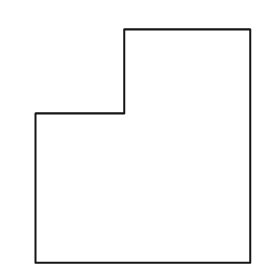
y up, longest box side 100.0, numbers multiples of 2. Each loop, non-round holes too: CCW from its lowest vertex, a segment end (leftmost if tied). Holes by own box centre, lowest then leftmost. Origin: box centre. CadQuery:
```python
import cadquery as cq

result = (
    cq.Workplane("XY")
    .moveTo(-46.0, -50.0)
    .lineTo(46.0, -50.0)
    .lineTo(46.0, 50.0)
    .lineTo(-8.0, 50.0)
    .lineTo(-8.0, 14.0)
    .lineTo(-46.0, 14.0)
    .close()
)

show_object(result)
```